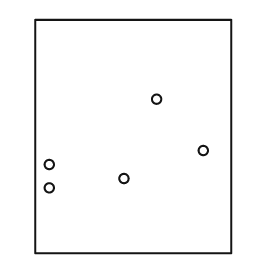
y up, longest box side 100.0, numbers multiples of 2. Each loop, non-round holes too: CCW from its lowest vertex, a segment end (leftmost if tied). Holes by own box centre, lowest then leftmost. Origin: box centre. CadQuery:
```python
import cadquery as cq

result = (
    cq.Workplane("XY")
    .moveTo(-42.0, -50.0)
    .lineTo(42.0, -50.0)
    .lineTo(42.0, 50.0)
    .lineTo(-42.0, 50.0)
    .close()
    .moveTo(-36.0, -22.0)
    .circle(2.0)
    .moveTo(-4.0, -18.0)
    .circle(2.0)
    .moveTo(-36.0, -12.0)
    .circle(2.0)
    .moveTo(30.0, -6.0)
    .circle(2.0)
    .moveTo(10.0, 16.0)
    .circle(2.0)
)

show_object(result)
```